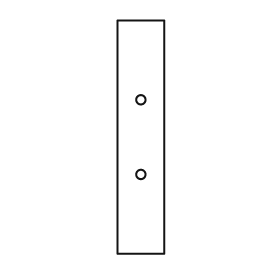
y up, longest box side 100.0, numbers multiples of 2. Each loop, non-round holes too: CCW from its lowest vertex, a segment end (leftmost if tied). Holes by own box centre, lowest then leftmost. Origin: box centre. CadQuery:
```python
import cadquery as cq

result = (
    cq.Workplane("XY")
    .moveTo(-10.0, -50.0)
    .lineTo(10.0, -50.0)
    .lineTo(10.0, 50.0)
    .lineTo(-10.0, 50.0)
    .close()
    .moveTo(0.0, -16.0)
    .circle(2.0)
    .moveTo(0.0, 16.0)
    .circle(2.0)
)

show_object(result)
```